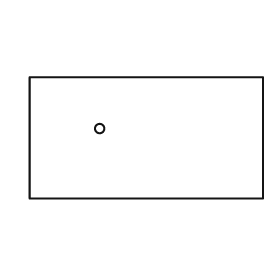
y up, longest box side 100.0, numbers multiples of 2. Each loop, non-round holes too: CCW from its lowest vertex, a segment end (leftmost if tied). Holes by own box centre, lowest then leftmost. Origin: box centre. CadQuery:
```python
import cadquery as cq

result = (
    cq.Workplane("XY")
    .moveTo(-50.0, -26.0)
    .lineTo(50.0, -26.0)
    .lineTo(50.0, 26.0)
    .lineTo(-50.0, 26.0)
    .close()
    .moveTo(-20.0, 4.0)
    .circle(2.0)
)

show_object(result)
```